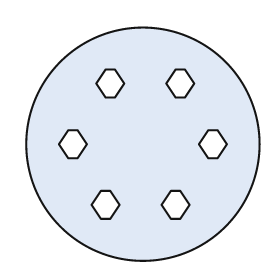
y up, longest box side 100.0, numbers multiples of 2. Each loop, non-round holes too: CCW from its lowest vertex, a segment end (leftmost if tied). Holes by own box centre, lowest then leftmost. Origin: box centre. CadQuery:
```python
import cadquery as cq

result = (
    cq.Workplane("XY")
    .moveTo(0.0, 0.0)
    .circle(50.0)
    .moveTo(-18.0, -32.0)
    .lineTo(-14.0, -32.0)
    .lineTo(-10.0, -26.0)
    .lineTo(-14.0, -20.0)
    .lineTo(-18.0, -20.0)
    .lineTo(-22.0, -26.0)
    .close()
    .moveTo(12.0, -32.0)
    .lineTo(16.0, -32.0)
    .lineTo(20.0, -26.0)
    .lineTo(16.0, -20.0)
    .lineTo(12.0, -20.0)
    .lineTo(8.0, -26.0)
    .close()
    .moveTo(-32.0, -6.0)
    .lineTo(-28.0, -6.0)
    .lineTo(-24.0, 0.0)
    .lineTo(-28.0, 6.0)
    .lineTo(-32.0, 6.0)
    .lineTo(-36.0, 0.0)
    .close()
    .moveTo(28.0, -6.0)
    .lineTo(32.0, -6.0)
    .lineTo(36.0, 0.0)
    .lineTo(32.0, 6.0)
    .lineTo(28.0, 6.0)
    .lineTo(24.0, 0.0)
    .close()
    .moveTo(-16.0, 20.0)
    .lineTo(-12.0, 20.0)
    .lineTo(-8.0, 26.0)
    .lineTo(-12.0, 32.0)
    .lineTo(-16.0, 32.0)
    .lineTo(-20.0, 26.0)
    .close()
    .moveTo(14.0, 20.0)
    .lineTo(18.0, 20.0)
    .lineTo(22.0, 26.0)
    .lineTo(18.0, 32.0)
    .lineTo(14.0, 32.0)
    .lineTo(10.0, 26.0)
    .close()
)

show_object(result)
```